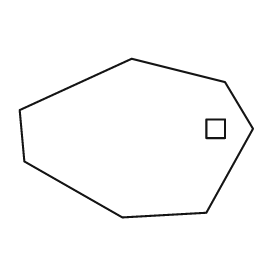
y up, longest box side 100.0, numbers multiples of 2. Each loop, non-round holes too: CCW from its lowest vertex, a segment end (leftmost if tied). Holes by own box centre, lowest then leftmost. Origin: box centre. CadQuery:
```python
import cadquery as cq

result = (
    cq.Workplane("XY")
    .moveTo(-6.0, -34.0)
    .lineTo(30.0, -32.0)
    .lineTo(50.0, 4.0)
    .lineTo(38.0, 24.0)
    .lineTo(-2.0, 34.0)
    .lineTo(-50.0, 12.0)
    .lineTo(-48.0, -10.0)
    .close()
    .moveTo(30.0, 0.0)
    .lineTo(38.0, 0.0)
    .lineTo(38.0, 8.0)
    .lineTo(30.0, 8.0)
    .close()
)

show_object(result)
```